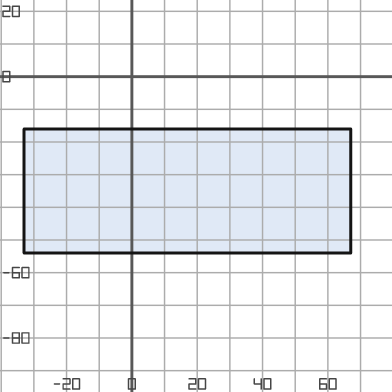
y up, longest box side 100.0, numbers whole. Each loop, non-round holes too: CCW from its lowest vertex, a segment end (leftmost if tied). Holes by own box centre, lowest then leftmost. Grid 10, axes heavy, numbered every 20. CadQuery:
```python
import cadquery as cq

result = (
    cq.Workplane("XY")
    .moveTo(-33.0, -54.0)
    .lineTo(67.0, -54.0)
    .lineTo(67.0, -16.0)
    .lineTo(-33.0, -16.0)
    .close()
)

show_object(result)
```